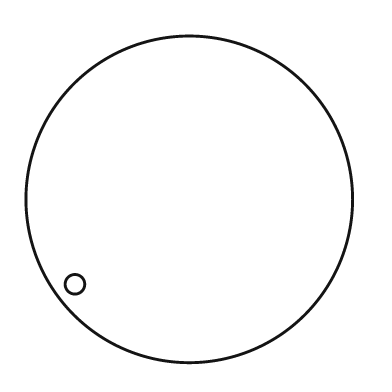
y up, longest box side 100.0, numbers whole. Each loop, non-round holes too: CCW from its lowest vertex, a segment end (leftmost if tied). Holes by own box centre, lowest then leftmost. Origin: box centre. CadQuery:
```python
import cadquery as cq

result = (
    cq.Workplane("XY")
    .moveTo(0.0, 0.0)
    .circle(50.0)
    .moveTo(-35.0, -26.0)
    .circle(3.0)
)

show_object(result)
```